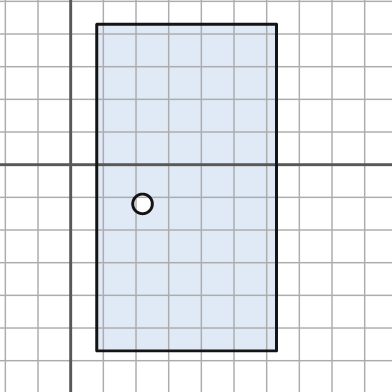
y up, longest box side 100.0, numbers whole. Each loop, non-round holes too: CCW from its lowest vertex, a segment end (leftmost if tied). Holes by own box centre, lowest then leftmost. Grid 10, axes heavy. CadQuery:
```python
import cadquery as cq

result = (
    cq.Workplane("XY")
    .moveTo(8.0, -57.0)
    .lineTo(63.0, -57.0)
    .lineTo(63.0, 43.0)
    .lineTo(8.0, 43.0)
    .close()
    .moveTo(22.0, -12.0)
    .circle(3.0)
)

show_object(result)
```